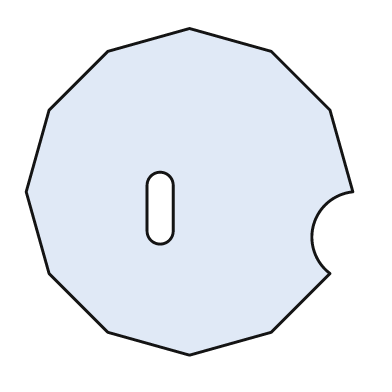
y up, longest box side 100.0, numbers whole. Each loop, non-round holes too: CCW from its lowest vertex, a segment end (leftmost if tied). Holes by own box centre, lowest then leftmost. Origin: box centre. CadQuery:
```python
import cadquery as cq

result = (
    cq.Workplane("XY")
    .moveTo(0.0, -50.0)
    .lineTo(25.0, -43.0)
    .lineTo(43.0, -25.0)
    .threePointArc((38.0, -10.0), (50.0, 0.0))
    .lineTo(43.0, 25.0)
    .lineTo(25.0, 43.0)
    .lineTo(0.0, 50.0)
    .lineTo(-25.0, 43.0)
    .lineTo(-43.0, 25.0)
    .lineTo(-50.0, 0.0)
    .lineTo(-43.0, -25.0)
    .lineTo(-25.0, -43.0)
    .close()
    .moveTo(-13.0, -12.0)
    .threePointArc((-9.0, -16.0), (-5.0, -12.0))
    .lineTo(-5.0, 2.0)
    .threePointArc((-9.0, 6.0), (-13.0, 2.0))
    .close()
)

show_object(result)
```